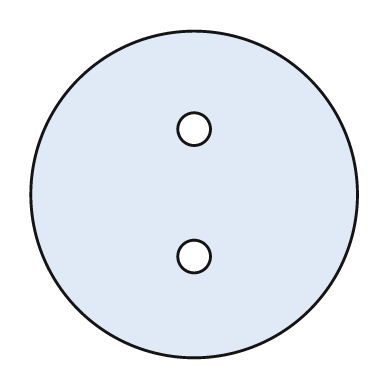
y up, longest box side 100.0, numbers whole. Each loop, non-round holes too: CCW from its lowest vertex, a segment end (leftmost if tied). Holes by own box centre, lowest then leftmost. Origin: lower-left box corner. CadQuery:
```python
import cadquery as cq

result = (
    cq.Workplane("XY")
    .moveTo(50.0, 50.0)
    .circle(50.0)
    .moveTo(50.0, 31.0)
    .circle(5.0)
    .moveTo(50.0, 70.0)
    .circle(5.0)
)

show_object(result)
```